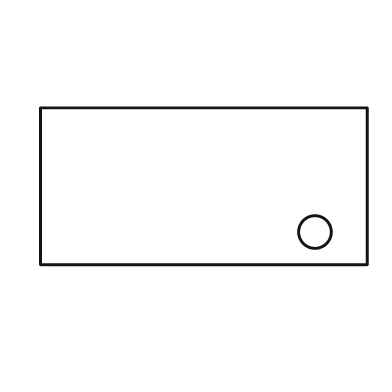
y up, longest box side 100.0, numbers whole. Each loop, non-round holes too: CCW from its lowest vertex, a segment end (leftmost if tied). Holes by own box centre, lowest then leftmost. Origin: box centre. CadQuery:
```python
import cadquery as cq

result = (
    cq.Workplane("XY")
    .moveTo(-50.0, -24.0)
    .lineTo(50.0, -24.0)
    .lineTo(50.0, 24.0)
    .lineTo(-50.0, 24.0)
    .close()
    .moveTo(34.0, -14.0)
    .circle(5.0)
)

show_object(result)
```